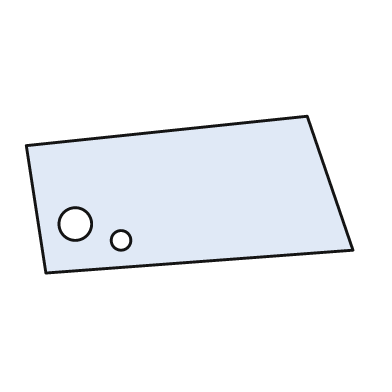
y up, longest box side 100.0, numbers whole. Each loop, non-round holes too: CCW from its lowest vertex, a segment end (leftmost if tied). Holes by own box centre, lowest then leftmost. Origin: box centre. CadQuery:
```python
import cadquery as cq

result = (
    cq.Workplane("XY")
    .moveTo(-44.0, -24.0)
    .lineTo(50.0, -17.0)
    .lineTo(36.0, 24.0)
    .lineTo(-50.0, 15.0)
    .close()
    .moveTo(-21.0, -14.0)
    .circle(3.0)
    .moveTo(-35.0, -9.0)
    .circle(5.0)
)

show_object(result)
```